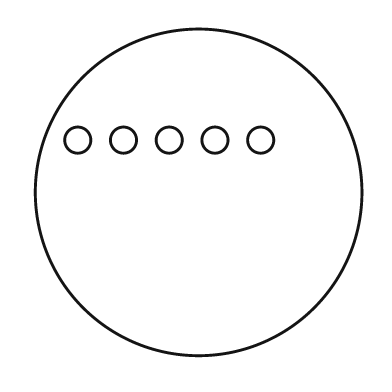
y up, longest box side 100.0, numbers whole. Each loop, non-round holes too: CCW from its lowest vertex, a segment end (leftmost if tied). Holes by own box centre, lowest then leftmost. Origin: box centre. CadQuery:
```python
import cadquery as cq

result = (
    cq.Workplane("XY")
    .moveTo(0.0, 0.0)
    .circle(50.0)
    .moveTo(-37.0, 16.0)
    .circle(4.0)
    .moveTo(-23.0, 16.0)
    .circle(4.0)
    .moveTo(-9.0, 16.0)
    .circle(4.0)
    .moveTo(5.0, 16.0)
    .circle(4.0)
    .moveTo(19.0, 16.0)
    .circle(4.0)
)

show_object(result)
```